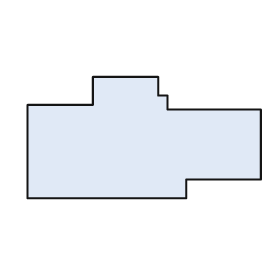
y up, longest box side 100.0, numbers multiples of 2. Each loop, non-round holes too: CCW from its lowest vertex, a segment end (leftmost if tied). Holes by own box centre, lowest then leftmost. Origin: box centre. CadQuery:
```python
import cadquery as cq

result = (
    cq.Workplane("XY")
    .moveTo(-50.0, -26.0)
    .lineTo(18.0, -26.0)
    .lineTo(18.0, -18.0)
    .lineTo(50.0, -18.0)
    .lineTo(50.0, 12.0)
    .lineTo(10.0, 12.0)
    .lineTo(10.0, 18.0)
    .lineTo(6.0, 18.0)
    .lineTo(6.0, 26.0)
    .lineTo(-22.0, 26.0)
    .lineTo(-22.0, 14.0)
    .lineTo(-50.0, 14.0)
    .close()
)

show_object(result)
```